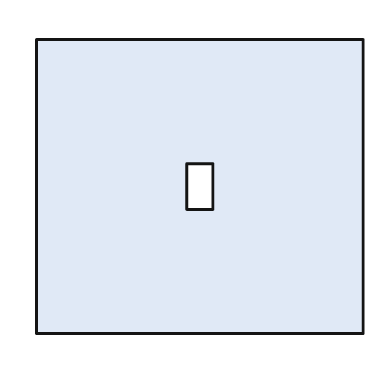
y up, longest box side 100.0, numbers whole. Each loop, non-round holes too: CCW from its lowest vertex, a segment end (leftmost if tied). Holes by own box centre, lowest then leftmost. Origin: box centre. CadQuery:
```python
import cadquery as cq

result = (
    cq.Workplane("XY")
    .moveTo(-50.0, -45.0)
    .lineTo(50.0, -45.0)
    .lineTo(50.0, 45.0)
    .lineTo(-50.0, 45.0)
    .close()
    .moveTo(-4.0, -7.0)
    .lineTo(4.0, -7.0)
    .lineTo(4.0, 7.0)
    .lineTo(-4.0, 7.0)
    .close()
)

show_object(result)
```